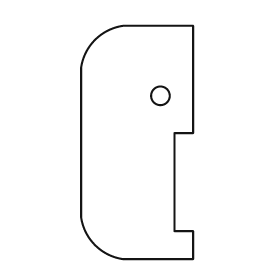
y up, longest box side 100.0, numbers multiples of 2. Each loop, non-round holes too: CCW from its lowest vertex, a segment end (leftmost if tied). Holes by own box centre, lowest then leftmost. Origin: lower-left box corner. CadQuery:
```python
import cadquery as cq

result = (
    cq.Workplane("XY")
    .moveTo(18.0, 0.0)
    .lineTo(48.0, 0.0)
    .lineTo(48.0, 12.0)
    .lineTo(40.0, 12.0)
    .lineTo(40.0, 54.0)
    .lineTo(48.0, 54.0)
    .lineTo(48.0, 100.0)
    .lineTo(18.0, 100.0)
    .threePointArc((6.0, 94.0), (0.0, 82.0))
    .lineTo(0.0, 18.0)
    .threePointArc((6.0, 6.0), (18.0, 0.0))
    .close()
    .moveTo(34.0, 70.0)
    .circle(4.0)
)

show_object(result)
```